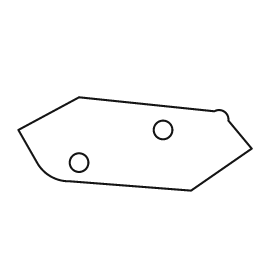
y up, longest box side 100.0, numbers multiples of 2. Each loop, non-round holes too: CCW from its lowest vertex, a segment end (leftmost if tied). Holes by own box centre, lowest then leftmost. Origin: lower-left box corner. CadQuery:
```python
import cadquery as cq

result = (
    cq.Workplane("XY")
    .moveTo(74.0, 0.0)
    .lineTo(100.0, 18.0)
    .lineTo(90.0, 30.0)
    .threePointArc((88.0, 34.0), (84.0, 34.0))
    .lineTo(26.0, 40.0)
    .lineTo(0.0, 26.0)
    .lineTo(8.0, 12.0)
    .threePointArc((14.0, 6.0), (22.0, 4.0))
    .close()
    .moveTo(26.0, 12.0)
    .circle(4.0)
    .moveTo(62.0, 26.0)
    .circle(4.0)
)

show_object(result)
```